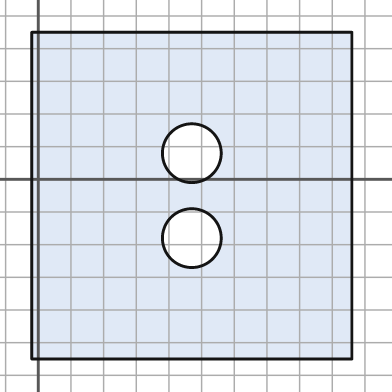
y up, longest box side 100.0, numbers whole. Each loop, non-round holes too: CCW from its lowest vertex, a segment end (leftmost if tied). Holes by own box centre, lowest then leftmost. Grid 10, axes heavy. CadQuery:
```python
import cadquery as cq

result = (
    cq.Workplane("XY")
    .moveTo(-2.0, -55.0)
    .lineTo(96.0, -55.0)
    .lineTo(96.0, 45.0)
    .lineTo(-2.0, 45.0)
    .close()
    .moveTo(47.0, -18.0)
    .circle(9.0)
    .moveTo(47.0, 8.0)
    .circle(9.0)
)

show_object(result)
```